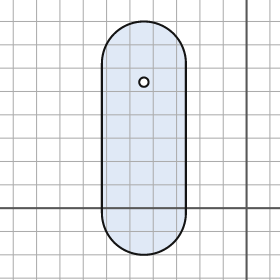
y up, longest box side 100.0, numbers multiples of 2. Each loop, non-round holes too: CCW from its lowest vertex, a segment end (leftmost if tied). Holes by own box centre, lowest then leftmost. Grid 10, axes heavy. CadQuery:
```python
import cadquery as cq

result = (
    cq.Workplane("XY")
    .moveTo(-62.0, -2.0)
    .threePointArc((-44.0, -20.0), (-26.0, -2.0))
    .lineTo(-26.0, 62.0)
    .threePointArc((-44.0, 80.0), (-62.0, 62.0))
    .close()
    .moveTo(-44.0, 54.0)
    .circle(2.0)
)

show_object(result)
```